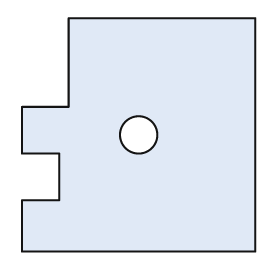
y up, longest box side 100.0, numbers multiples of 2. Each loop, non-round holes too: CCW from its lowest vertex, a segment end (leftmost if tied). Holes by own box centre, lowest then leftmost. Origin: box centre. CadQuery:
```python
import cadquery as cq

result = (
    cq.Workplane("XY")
    .moveTo(-50.0, -50.0)
    .lineTo(50.0, -50.0)
    .lineTo(50.0, 50.0)
    .lineTo(-30.0, 50.0)
    .lineTo(-30.0, 12.0)
    .lineTo(-50.0, 12.0)
    .lineTo(-50.0, -8.0)
    .lineTo(-34.0, -8.0)
    .lineTo(-34.0, -28.0)
    .lineTo(-50.0, -28.0)
    .close()
    .moveTo(0.0, 0.0)
    .circle(8.0)
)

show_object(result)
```